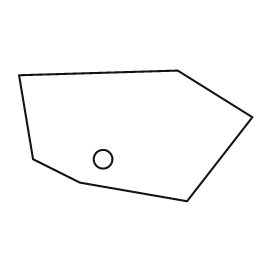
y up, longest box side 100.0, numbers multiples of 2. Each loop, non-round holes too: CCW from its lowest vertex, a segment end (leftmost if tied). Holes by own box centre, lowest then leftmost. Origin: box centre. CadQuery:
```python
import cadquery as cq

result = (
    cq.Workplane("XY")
    .moveTo(22.0, -28.0)
    .lineTo(50.0, 8.0)
    .lineTo(18.0, 28.0)
    .lineTo(-50.0, 26.0)
    .lineTo(-44.0, -10.0)
    .lineTo(-24.0, -20.0)
    .close()
    .moveTo(-14.0, -10.0)
    .circle(4.0)
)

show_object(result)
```